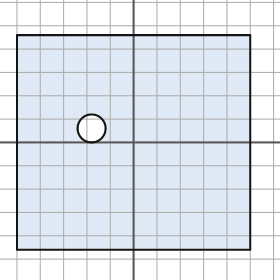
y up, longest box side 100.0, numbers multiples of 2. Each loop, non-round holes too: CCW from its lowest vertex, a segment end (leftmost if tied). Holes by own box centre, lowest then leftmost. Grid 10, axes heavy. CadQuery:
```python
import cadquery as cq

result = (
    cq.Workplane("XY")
    .moveTo(-50.0, -46.0)
    .lineTo(50.0, -46.0)
    .lineTo(50.0, 46.0)
    .lineTo(-50.0, 46.0)
    .close()
    .moveTo(-18.0, 6.0)
    .circle(6.0)
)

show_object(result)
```